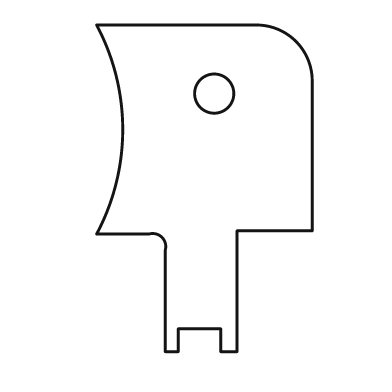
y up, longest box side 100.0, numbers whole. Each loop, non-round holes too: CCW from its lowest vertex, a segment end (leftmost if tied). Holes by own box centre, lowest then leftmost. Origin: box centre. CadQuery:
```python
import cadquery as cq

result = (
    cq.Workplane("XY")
    .moveTo(-12.0, -50.0)
    .lineTo(-8.0, -50.0)
    .lineTo(-8.0, -43.0)
    .lineTo(5.0, -43.0)
    .lineTo(5.0, -50.0)
    .lineTo(10.0, -50.0)
    .lineTo(10.0, -13.0)
    .lineTo(33.0, -13.0)
    .lineTo(33.0, 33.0)
    .threePointArc((28.0, 45.0), (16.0, 50.0))
    .lineTo(-33.0, 50.0)
    .threePointArc((-25.0, 18.0), (-33.0, -14.0))
    .lineTo(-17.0, -14.0)
    .threePointArc((-13.0, -15.0), (-12.0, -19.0))
    .close()
    .moveTo(3.0, 29.0)
    .circle(6.0)
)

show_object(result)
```